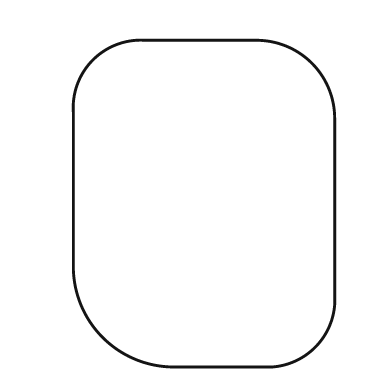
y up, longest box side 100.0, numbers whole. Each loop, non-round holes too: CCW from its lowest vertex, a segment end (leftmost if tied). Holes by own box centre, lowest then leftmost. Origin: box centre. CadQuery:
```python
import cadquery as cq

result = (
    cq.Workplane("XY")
    .moveTo(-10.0, -50.0)
    .lineTo(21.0, -50.0)
    .threePointArc((34.0, -44.0), (40.0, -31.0))
    .lineTo(40.0, 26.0)
    .threePointArc((33.0, 43.0), (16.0, 50.0))
    .lineTo(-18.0, 50.0)
    .threePointArc((-34.0, 44.0), (-40.0, 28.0))
    .lineTo(-40.0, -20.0)
    .threePointArc((-31.0, -41.0), (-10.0, -50.0))
    .close()
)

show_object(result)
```